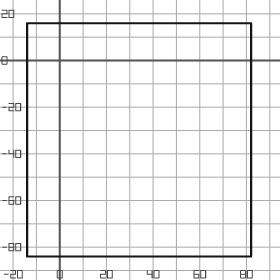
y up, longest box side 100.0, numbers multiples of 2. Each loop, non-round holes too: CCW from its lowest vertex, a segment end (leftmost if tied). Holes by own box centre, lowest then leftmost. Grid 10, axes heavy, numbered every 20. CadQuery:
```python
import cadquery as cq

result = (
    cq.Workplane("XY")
    .moveTo(-14.0, -84.0)
    .lineTo(82.0, -84.0)
    .lineTo(82.0, 16.0)
    .lineTo(-14.0, 16.0)
    .close()
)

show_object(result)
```